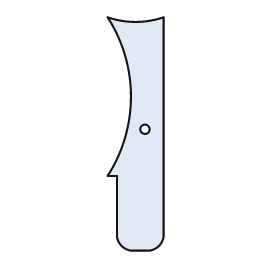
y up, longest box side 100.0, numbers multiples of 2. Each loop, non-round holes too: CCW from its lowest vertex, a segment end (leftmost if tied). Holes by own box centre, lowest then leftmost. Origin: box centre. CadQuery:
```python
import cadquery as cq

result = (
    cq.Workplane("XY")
    .moveTo(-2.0, -50.0)
    .lineTo(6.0, -50.0)
    .threePointArc((10.0, -48.0), (12.0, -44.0))
    .lineTo(12.0, 50.0)
    .threePointArc((0.0, 48.0), (-12.0, 50.0))
    .threePointArc((-2.0, 16.0), (-12.0, -18.0))
    .lineTo(-8.0, -18.0)
    .lineTo(-8.0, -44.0)
    .threePointArc((-6.0, -48.0), (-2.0, -50.0))
    .close()
    .moveTo(4.0, 2.0)
    .circle(2.0)
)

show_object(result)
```